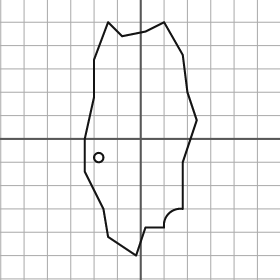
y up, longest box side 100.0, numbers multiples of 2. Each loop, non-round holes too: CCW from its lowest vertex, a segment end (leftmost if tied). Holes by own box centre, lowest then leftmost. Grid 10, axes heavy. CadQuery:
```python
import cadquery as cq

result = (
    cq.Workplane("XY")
    .moveTo(-2.0, -50.0)
    .lineTo(2.0, -38.0)
    .lineTo(10.0, -38.0)
    .threePointArc((12.0, -32.0), (18.0, -30.0))
    .lineTo(18.0, -10.0)
    .lineTo(24.0, 8.0)
    .lineTo(20.0, 20.0)
    .lineTo(18.0, 36.0)
    .lineTo(10.0, 50.0)
    .lineTo(2.0, 46.0)
    .lineTo(-8.0, 44.0)
    .lineTo(-14.0, 50.0)
    .lineTo(-20.0, 34.0)
    .lineTo(-20.0, 18.0)
    .lineTo(-24.0, 0.0)
    .lineTo(-24.0, -14.0)
    .lineTo(-16.0, -30.0)
    .lineTo(-14.0, -42.0)
    .close()
    .moveTo(-18.0, -8.0)
    .circle(2.0)
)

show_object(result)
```